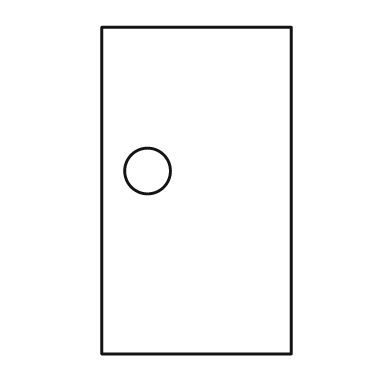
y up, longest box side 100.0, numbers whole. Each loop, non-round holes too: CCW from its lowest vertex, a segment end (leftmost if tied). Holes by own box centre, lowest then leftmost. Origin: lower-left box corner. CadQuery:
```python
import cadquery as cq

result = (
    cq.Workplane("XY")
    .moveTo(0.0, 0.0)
    .lineTo(58.0, 0.0)
    .lineTo(58.0, 100.0)
    .lineTo(0.0, 100.0)
    .close()
    .moveTo(14.0, 56.0)
    .circle(7.0)
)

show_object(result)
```